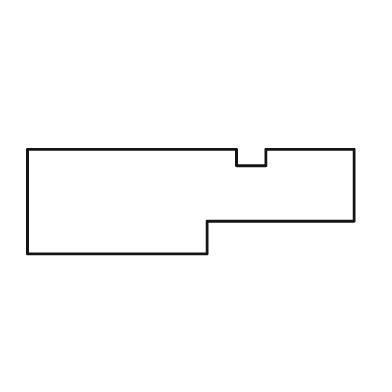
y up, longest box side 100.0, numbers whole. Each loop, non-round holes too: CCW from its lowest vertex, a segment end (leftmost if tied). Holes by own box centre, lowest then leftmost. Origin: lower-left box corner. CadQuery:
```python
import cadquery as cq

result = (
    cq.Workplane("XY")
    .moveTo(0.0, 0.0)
    .lineTo(55.0, 0.0)
    .lineTo(55.0, 10.0)
    .lineTo(100.0, 10.0)
    .lineTo(100.0, 32.0)
    .lineTo(73.0, 32.0)
    .lineTo(73.0, 27.0)
    .lineTo(64.0, 27.0)
    .lineTo(64.0, 32.0)
    .lineTo(0.0, 32.0)
    .close()
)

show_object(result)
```